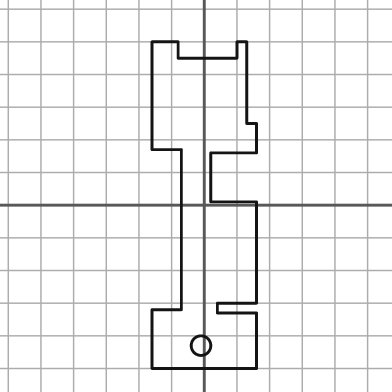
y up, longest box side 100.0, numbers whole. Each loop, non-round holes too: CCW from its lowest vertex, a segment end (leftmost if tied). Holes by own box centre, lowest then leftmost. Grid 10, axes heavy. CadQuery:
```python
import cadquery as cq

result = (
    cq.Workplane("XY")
    .moveTo(-16.0, -50.0)
    .lineTo(16.0, -50.0)
    .lineTo(16.0, -33.0)
    .lineTo(4.0, -33.0)
    .lineTo(4.0, -30.0)
    .lineTo(16.0, -30.0)
    .lineTo(16.0, 1.0)
    .lineTo(2.0, 1.0)
    .lineTo(2.0, 16.0)
    .lineTo(16.0, 16.0)
    .lineTo(16.0, 25.0)
    .lineTo(13.0, 25.0)
    .lineTo(13.0, 50.0)
    .lineTo(10.0, 50.0)
    .lineTo(10.0, 45.0)
    .lineTo(-8.0, 45.0)
    .lineTo(-8.0, 50.0)
    .lineTo(-16.0, 50.0)
    .lineTo(-16.0, 17.0)
    .lineTo(-7.0, 17.0)
    .lineTo(-7.0, -32.0)
    .lineTo(-16.0, -32.0)
    .close()
    .moveTo(-1.0, -43.0)
    .circle(3.0)
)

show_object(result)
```